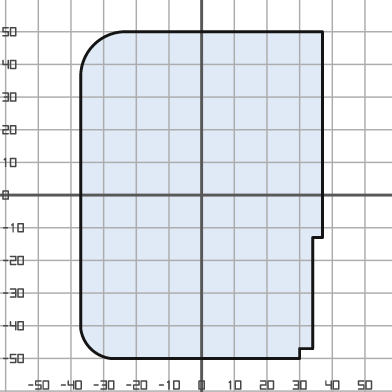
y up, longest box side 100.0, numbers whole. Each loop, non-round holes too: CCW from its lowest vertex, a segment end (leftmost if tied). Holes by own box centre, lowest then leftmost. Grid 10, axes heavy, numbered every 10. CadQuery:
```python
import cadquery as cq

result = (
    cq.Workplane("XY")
    .moveTo(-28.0, -50.0)
    .lineTo(30.0, -50.0)
    .lineTo(30.0, -47.0)
    .lineTo(34.0, -47.0)
    .lineTo(34.0, -13.0)
    .lineTo(37.0, -13.0)
    .lineTo(37.0, 50.0)
    .lineTo(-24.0, 50.0)
    .threePointArc((-33.0, 46.0), (-37.0, 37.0))
    .lineTo(-37.0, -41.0)
    .threePointArc((-34.0, -47.0), (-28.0, -50.0))
    .close()
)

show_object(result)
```